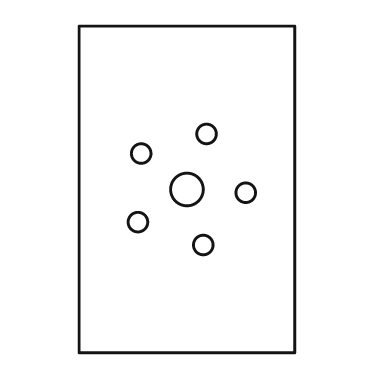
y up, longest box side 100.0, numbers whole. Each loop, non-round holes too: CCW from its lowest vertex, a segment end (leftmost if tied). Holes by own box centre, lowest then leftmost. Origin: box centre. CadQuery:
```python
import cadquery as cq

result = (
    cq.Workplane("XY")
    .moveTo(-33.0, -50.0)
    .lineTo(33.0, -50.0)
    .lineTo(33.0, 50.0)
    .lineTo(-33.0, 50.0)
    .close()
    .moveTo(5.0, -17.0)
    .circle(3.0)
    .moveTo(-15.0, -10.0)
    .circle(3.0)
    .moveTo(18.0, -1.0)
    .circle(3.0)
    .moveTo(0.0, 0.0)
    .circle(5.0)
    .moveTo(-14.0, 11.0)
    .circle(3.0)
    .moveTo(6.0, 17.0)
    .circle(3.0)
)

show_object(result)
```